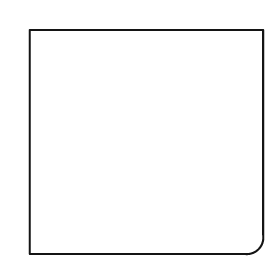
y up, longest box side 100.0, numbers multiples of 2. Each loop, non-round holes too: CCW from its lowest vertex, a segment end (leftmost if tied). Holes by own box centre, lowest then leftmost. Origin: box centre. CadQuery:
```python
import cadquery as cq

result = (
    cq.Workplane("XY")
    .moveTo(-50.0, -48.0)
    .lineTo(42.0, -48.0)
    .threePointArc((48.0, -46.0), (50.0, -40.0))
    .lineTo(50.0, 48.0)
    .lineTo(-50.0, 48.0)
    .close()
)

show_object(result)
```